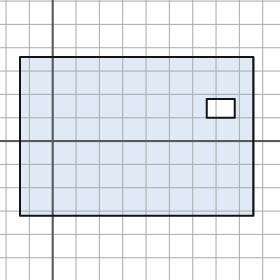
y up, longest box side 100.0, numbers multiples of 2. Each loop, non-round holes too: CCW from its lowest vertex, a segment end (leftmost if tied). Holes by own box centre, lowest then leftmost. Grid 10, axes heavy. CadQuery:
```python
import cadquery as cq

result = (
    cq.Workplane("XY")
    .moveTo(-14.0, -32.0)
    .lineTo(86.0, -32.0)
    .lineTo(86.0, 36.0)
    .lineTo(-14.0, 36.0)
    .close()
    .moveTo(66.0, 10.0)
    .lineTo(78.0, 10.0)
    .lineTo(78.0, 18.0)
    .lineTo(66.0, 18.0)
    .close()
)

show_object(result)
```